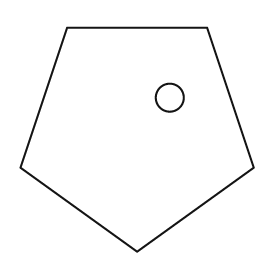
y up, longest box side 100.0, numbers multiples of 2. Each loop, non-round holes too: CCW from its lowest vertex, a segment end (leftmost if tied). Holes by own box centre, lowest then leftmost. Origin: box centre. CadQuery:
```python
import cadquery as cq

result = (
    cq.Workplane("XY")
    .moveTo(0.0, -48.0)
    .lineTo(50.0, -12.0)
    .lineTo(30.0, 48.0)
    .lineTo(-30.0, 48.0)
    .lineTo(-50.0, -12.0)
    .close()
    .moveTo(14.0, 18.0)
    .circle(6.0)
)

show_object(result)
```